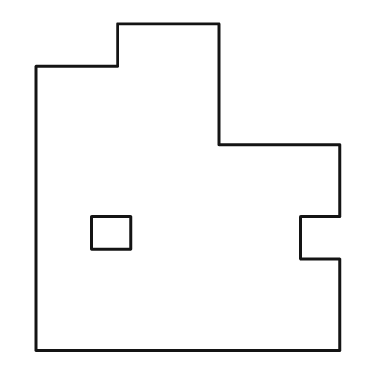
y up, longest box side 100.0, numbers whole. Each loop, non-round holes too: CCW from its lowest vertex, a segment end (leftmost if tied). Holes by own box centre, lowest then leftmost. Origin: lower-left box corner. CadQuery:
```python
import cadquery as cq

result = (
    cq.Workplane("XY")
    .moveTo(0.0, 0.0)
    .lineTo(93.0, 0.0)
    .lineTo(93.0, 28.0)
    .lineTo(81.0, 28.0)
    .lineTo(81.0, 41.0)
    .lineTo(93.0, 41.0)
    .lineTo(93.0, 63.0)
    .lineTo(56.0, 63.0)
    .lineTo(56.0, 100.0)
    .lineTo(25.0, 100.0)
    .lineTo(25.0, 87.0)
    .lineTo(0.0, 87.0)
    .close()
    .moveTo(17.0, 31.0)
    .lineTo(29.0, 31.0)
    .lineTo(29.0, 41.0)
    .lineTo(17.0, 41.0)
    .close()
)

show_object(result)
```